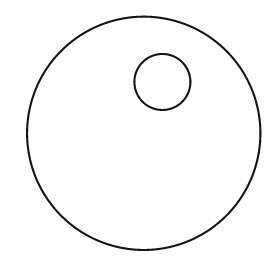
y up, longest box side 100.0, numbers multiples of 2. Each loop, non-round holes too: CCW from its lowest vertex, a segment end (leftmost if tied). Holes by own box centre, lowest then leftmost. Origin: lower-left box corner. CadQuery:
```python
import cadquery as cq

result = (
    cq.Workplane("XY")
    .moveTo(50.0, 50.0)
    .circle(50.0)
    .moveTo(58.0, 72.0)
    .circle(12.0)
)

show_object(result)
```